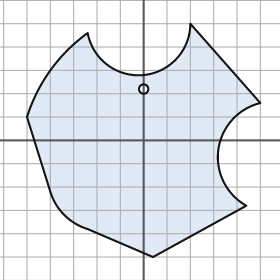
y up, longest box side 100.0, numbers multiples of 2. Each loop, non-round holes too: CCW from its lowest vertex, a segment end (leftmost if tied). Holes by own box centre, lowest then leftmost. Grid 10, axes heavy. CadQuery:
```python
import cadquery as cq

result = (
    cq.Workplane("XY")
    .moveTo(4.0, -50.0)
    .lineTo(44.0, -28.0)
    .threePointArc((32.0, -4.0), (50.0, 16.0))
    .lineTo(20.0, 50.0)
    .threePointArc((0.0, 28.0), (-24.0, 46.0))
    .threePointArc((-40.0, 30.0), (-50.0, 10.0))
    .lineTo(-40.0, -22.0)
    .threePointArc((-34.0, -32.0), (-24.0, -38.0))
    .close()
    .moveTo(0.0, 22.0)
    .circle(2.0)
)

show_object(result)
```